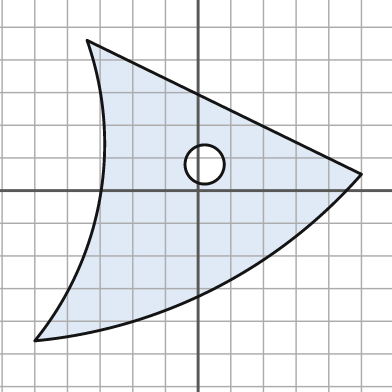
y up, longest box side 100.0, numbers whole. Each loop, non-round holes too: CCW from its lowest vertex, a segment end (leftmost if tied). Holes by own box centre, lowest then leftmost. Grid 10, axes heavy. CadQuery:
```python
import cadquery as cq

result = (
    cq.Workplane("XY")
    .moveTo(-50.0, -46.0)
    .threePointArc((5.0, -30.0), (50.0, 5.0))
    .lineTo(-34.0, 46.0)
    .threePointArc((-30.0, -2.0), (-50.0, -46.0))
    .close()
    .moveTo(2.0, 8.0)
    .circle(6.0)
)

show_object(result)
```